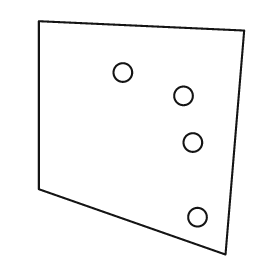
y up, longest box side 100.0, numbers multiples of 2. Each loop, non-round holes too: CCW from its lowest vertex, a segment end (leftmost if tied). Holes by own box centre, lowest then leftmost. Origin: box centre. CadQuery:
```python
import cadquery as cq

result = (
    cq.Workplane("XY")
    .moveTo(36.0, -50.0)
    .lineTo(44.0, 46.0)
    .lineTo(-44.0, 50.0)
    .lineTo(-44.0, -22.0)
    .close()
    .moveTo(24.0, -34.0)
    .circle(4.0)
    .moveTo(22.0, -2.0)
    .circle(4.0)
    .moveTo(18.0, 18.0)
    .circle(4.0)
    .moveTo(-8.0, 28.0)
    .circle(4.0)
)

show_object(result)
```